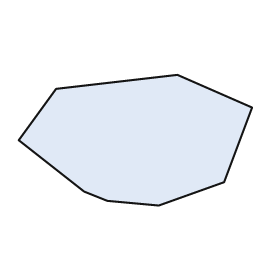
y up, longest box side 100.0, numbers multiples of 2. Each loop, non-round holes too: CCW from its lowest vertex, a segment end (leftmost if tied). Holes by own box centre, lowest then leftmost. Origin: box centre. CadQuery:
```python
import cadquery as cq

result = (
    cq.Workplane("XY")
    .moveTo(10.0, -28.0)
    .lineTo(38.0, -18.0)
    .lineTo(50.0, 14.0)
    .lineTo(18.0, 28.0)
    .lineTo(-34.0, 22.0)
    .lineTo(-50.0, 0.0)
    .lineTo(-22.0, -22.0)
    .lineTo(-12.0, -26.0)
    .close()
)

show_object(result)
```